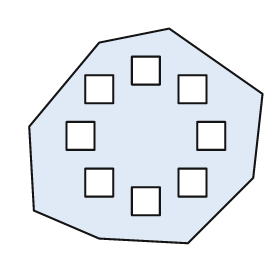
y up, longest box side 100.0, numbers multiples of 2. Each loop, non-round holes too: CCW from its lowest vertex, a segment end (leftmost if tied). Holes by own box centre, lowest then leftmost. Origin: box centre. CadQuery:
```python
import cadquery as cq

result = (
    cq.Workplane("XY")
    .moveTo(18.0, -46.0)
    .lineTo(46.0, -18.0)
    .lineTo(50.0, 18.0)
    .lineTo(10.0, 46.0)
    .lineTo(-20.0, 40.0)
    .lineTo(-50.0, 4.0)
    .lineTo(-48.0, -32.0)
    .lineTo(-20.0, -44.0)
    .close()
    .moveTo(-6.0, -34.0)
    .lineTo(6.0, -34.0)
    .lineTo(6.0, -22.0)
    .lineTo(-6.0, -22.0)
    .close()
    .moveTo(-26.0, -26.0)
    .lineTo(-14.0, -26.0)
    .lineTo(-14.0, -14.0)
    .lineTo(-26.0, -14.0)
    .close()
    .moveTo(14.0, -26.0)
    .lineTo(26.0, -26.0)
    .lineTo(26.0, -14.0)
    .lineTo(14.0, -14.0)
    .close()
    .moveTo(-34.0, -6.0)
    .lineTo(-22.0, -6.0)
    .lineTo(-22.0, 6.0)
    .lineTo(-34.0, 6.0)
    .close()
    .moveTo(22.0, -6.0)
    .lineTo(34.0, -6.0)
    .lineTo(34.0, 6.0)
    .lineTo(22.0, 6.0)
    .close()
    .moveTo(-26.0, 14.0)
    .lineTo(-14.0, 14.0)
    .lineTo(-14.0, 26.0)
    .lineTo(-26.0, 26.0)
    .close()
    .moveTo(14.0, 14.0)
    .lineTo(26.0, 14.0)
    .lineTo(26.0, 26.0)
    .lineTo(14.0, 26.0)
    .close()
    .moveTo(-6.0, 22.0)
    .lineTo(6.0, 22.0)
    .lineTo(6.0, 34.0)
    .lineTo(-6.0, 34.0)
    .close()
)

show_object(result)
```